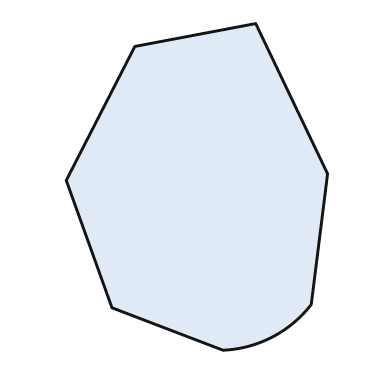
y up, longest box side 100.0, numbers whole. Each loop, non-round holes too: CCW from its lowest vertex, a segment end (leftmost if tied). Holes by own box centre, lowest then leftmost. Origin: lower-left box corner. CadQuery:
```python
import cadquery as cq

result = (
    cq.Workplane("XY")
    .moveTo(48.0, 0.0)
    .threePointArc((63.0, 4.0), (75.0, 14.0))
    .lineTo(80.0, 54.0)
    .lineTo(58.0, 100.0)
    .lineTo(21.0, 93.0)
    .lineTo(0.0, 52.0)
    .lineTo(14.0, 13.0)
    .close()
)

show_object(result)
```